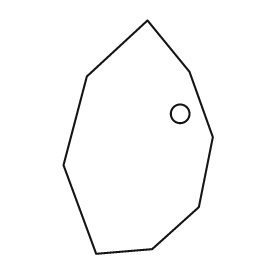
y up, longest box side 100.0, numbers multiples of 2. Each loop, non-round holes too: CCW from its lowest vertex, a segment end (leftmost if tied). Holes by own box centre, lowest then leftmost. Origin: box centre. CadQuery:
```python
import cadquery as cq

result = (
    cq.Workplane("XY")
    .moveTo(-18.0, -50.0)
    .lineTo(6.0, -48.0)
    .lineTo(26.0, -30.0)
    .lineTo(32.0, 0.0)
    .lineTo(22.0, 28.0)
    .lineTo(4.0, 50.0)
    .lineTo(-22.0, 26.0)
    .lineTo(-32.0, -12.0)
    .close()
    .moveTo(18.0, 10.0)
    .circle(4.0)
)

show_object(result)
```